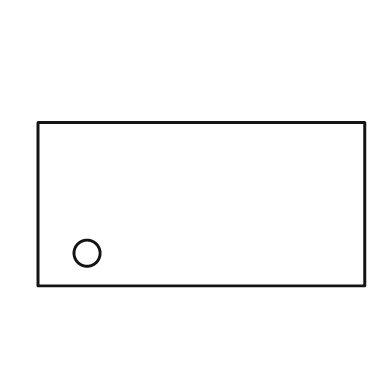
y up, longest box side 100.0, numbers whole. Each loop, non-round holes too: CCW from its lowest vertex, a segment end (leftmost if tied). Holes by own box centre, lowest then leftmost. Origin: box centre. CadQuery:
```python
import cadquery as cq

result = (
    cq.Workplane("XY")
    .moveTo(-50.0, -25.0)
    .lineTo(50.0, -25.0)
    .lineTo(50.0, 25.0)
    .lineTo(-50.0, 25.0)
    .close()
    .moveTo(-35.0, -15.0)
    .circle(4.0)
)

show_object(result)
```